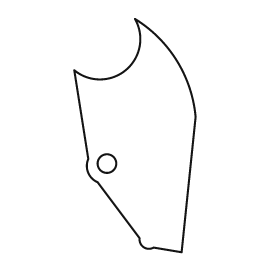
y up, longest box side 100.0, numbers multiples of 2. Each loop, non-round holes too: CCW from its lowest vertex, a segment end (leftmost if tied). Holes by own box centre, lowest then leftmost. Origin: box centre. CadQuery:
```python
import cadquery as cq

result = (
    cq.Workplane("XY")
    .moveTo(20.0, -50.0)
    .lineTo(26.0, 8.0)
    .threePointArc((18.0, 32.0), (0.0, 50.0))
    .threePointArc((-4.0, 28.0), (-26.0, 28.0))
    .lineTo(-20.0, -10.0)
    .threePointArc((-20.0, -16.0), (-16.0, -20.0))
    .lineTo(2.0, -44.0)
    .threePointArc((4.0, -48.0), (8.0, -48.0))
    .close()
    .moveTo(-12.0, -12.0)
    .circle(4.0)
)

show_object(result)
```